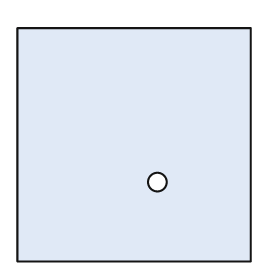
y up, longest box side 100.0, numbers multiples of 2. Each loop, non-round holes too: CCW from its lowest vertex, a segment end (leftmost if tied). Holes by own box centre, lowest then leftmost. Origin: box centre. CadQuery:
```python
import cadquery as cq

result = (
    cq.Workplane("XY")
    .moveTo(-50.0, -50.0)
    .lineTo(50.0, -50.0)
    .lineTo(50.0, 50.0)
    .lineTo(-50.0, 50.0)
    .close()
    .moveTo(10.0, -16.0)
    .circle(4.0)
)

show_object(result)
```